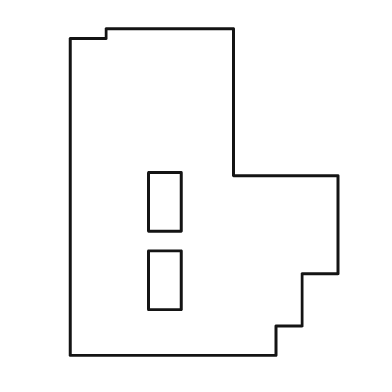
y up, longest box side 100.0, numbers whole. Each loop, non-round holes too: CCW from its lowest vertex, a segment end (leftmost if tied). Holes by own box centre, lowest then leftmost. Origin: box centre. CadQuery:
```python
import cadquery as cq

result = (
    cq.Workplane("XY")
    .moveTo(-41.0, -50.0)
    .lineTo(22.0, -50.0)
    .lineTo(22.0, -41.0)
    .lineTo(30.0, -41.0)
    .lineTo(30.0, -25.0)
    .lineTo(41.0, -25.0)
    .lineTo(41.0, 5.0)
    .lineTo(9.0, 5.0)
    .lineTo(9.0, 50.0)
    .lineTo(-30.0, 50.0)
    .lineTo(-30.0, 47.0)
    .lineTo(-41.0, 47.0)
    .close()
    .moveTo(-17.0, -36.0)
    .lineTo(-7.0, -36.0)
    .lineTo(-7.0, -18.0)
    .lineTo(-17.0, -18.0)
    .close()
    .moveTo(-17.0, -12.0)
    .lineTo(-7.0, -12.0)
    .lineTo(-7.0, 6.0)
    .lineTo(-17.0, 6.0)
    .close()
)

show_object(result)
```